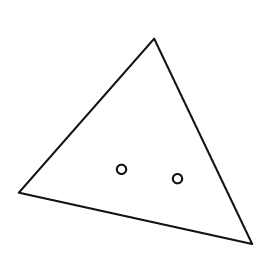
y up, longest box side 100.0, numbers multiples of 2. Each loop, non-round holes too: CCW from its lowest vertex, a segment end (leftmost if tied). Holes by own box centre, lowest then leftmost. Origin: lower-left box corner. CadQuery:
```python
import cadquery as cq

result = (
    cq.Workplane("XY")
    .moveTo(100.0, 0.0)
    .lineTo(58.0, 88.0)
    .lineTo(0.0, 22.0)
    .close()
    .moveTo(68.0, 28.0)
    .circle(2.0)
    .moveTo(44.0, 32.0)
    .circle(2.0)
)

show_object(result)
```